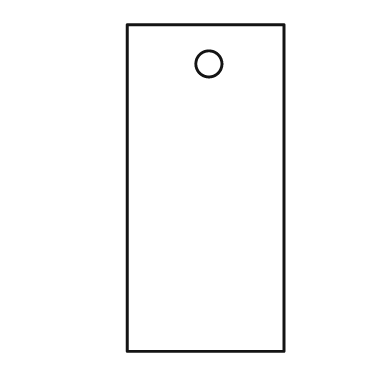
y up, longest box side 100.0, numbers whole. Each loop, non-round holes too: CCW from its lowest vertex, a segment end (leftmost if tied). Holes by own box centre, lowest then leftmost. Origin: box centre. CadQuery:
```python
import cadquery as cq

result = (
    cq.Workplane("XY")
    .moveTo(-24.0, -50.0)
    .lineTo(24.0, -50.0)
    .lineTo(24.0, 50.0)
    .lineTo(-24.0, 50.0)
    .close()
    .moveTo(1.0, 38.0)
    .circle(4.0)
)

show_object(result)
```